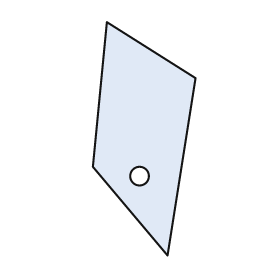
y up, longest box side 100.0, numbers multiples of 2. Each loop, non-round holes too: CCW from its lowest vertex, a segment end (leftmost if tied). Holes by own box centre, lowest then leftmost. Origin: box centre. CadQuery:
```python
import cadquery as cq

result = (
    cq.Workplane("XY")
    .moveTo(10.0, -50.0)
    .lineTo(22.0, 26.0)
    .lineTo(-16.0, 50.0)
    .lineTo(-22.0, -12.0)
    .close()
    .moveTo(-2.0, -16.0)
    .circle(4.0)
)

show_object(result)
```